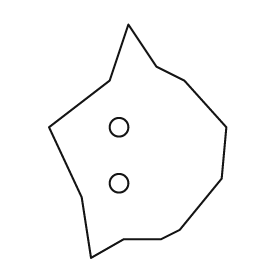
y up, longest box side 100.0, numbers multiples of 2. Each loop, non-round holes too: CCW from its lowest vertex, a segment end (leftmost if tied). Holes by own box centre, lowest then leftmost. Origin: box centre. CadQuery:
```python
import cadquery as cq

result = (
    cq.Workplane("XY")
    .moveTo(-20.0, -50.0)
    .lineTo(-6.0, -42.0)
    .lineTo(10.0, -42.0)
    .lineTo(18.0, -38.0)
    .lineTo(36.0, -16.0)
    .lineTo(38.0, 6.0)
    .lineTo(20.0, 26.0)
    .lineTo(8.0, 32.0)
    .lineTo(-4.0, 50.0)
    .lineTo(-12.0, 26.0)
    .lineTo(-38.0, 6.0)
    .lineTo(-24.0, -24.0)
    .close()
    .moveTo(-8.0, -18.0)
    .circle(4.0)
    .moveTo(-8.0, 6.0)
    .circle(4.0)
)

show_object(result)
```